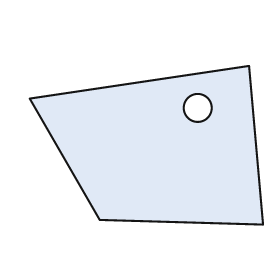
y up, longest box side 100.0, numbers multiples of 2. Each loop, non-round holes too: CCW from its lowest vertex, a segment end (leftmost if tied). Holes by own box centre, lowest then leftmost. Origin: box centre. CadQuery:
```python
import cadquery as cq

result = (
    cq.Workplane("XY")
    .moveTo(50.0, -34.0)
    .lineTo(44.0, 34.0)
    .lineTo(-50.0, 20.0)
    .lineTo(-20.0, -32.0)
    .close()
    .moveTo(22.0, 16.0)
    .circle(6.0)
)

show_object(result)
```